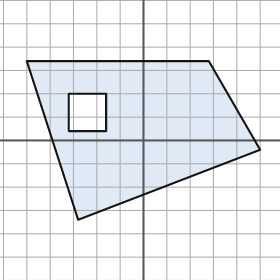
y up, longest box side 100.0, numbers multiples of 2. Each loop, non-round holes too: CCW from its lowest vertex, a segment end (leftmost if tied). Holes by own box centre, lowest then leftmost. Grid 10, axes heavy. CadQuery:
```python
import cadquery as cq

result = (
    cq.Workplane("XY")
    .moveTo(-28.0, -34.0)
    .lineTo(50.0, -4.0)
    .lineTo(28.0, 34.0)
    .lineTo(-50.0, 34.0)
    .close()
    .moveTo(-32.0, 4.0)
    .lineTo(-16.0, 4.0)
    .lineTo(-16.0, 20.0)
    .lineTo(-32.0, 20.0)
    .close()
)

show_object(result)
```